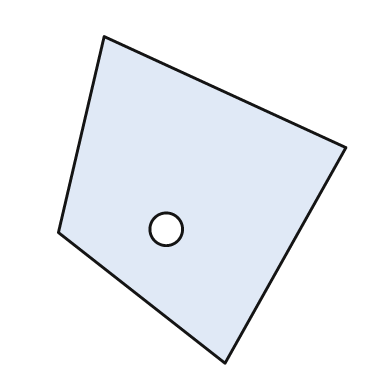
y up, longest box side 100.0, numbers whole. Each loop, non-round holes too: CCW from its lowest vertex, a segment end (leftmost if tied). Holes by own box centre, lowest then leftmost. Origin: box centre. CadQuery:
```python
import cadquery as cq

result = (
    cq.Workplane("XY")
    .moveTo(7.0, -50.0)
    .lineTo(44.0, 16.0)
    .lineTo(-30.0, 50.0)
    .lineTo(-44.0, -10.0)
    .close()
    .moveTo(-11.0, -9.0)
    .circle(5.0)
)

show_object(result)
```